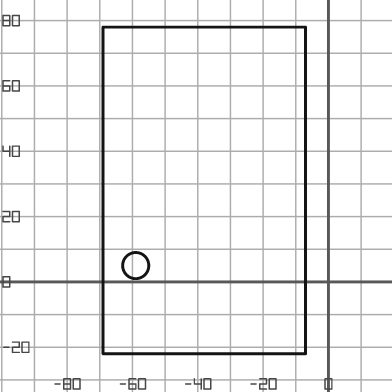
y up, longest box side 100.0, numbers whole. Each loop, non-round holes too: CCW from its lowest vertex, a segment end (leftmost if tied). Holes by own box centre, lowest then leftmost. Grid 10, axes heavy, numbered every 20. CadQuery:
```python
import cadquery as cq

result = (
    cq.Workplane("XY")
    .moveTo(-69.0, -22.0)
    .lineTo(-7.0, -22.0)
    .lineTo(-7.0, 78.0)
    .lineTo(-69.0, 78.0)
    .close()
    .moveTo(-59.0, 5.0)
    .circle(4.0)
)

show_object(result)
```